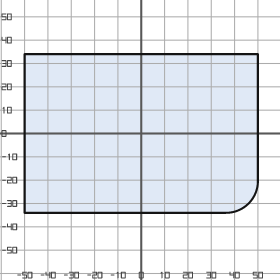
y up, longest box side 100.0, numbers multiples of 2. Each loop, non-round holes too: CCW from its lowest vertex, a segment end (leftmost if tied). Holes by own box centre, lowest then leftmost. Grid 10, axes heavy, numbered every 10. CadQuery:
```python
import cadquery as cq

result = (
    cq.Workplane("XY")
    .moveTo(-50.0, -34.0)
    .lineTo(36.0, -34.0)
    .threePointArc((46.0, -30.0), (50.0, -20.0))
    .lineTo(50.0, 34.0)
    .lineTo(-50.0, 34.0)
    .close()
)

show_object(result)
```